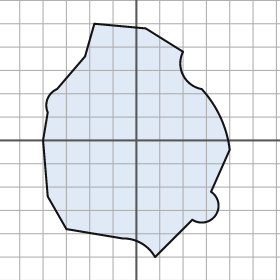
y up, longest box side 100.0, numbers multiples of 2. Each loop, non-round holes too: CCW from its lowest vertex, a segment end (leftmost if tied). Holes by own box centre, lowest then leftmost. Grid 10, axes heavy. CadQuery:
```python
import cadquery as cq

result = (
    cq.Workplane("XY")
    .moveTo(8.0, -50.0)
    .lineTo(24.0, -34.0)
    .threePointArc((34.0, -32.0), (32.0, -22.0))
    .lineTo(40.0, -4.0)
    .threePointArc((36.0, 10.0), (28.0, 22.0))
    .threePointArc((20.0, 28.0), (20.0, 38.0))
    .lineTo(4.0, 48.0)
    .lineTo(-18.0, 50.0)
    .lineTo(-22.0, 36.0)
    .lineTo(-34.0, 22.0)
    .threePointArc((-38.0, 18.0), (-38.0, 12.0))
    .lineTo(-40.0, 0.0)
    .lineTo(-38.0, -24.0)
    .lineTo(-30.0, -38.0)
    .lineTo(-6.0, -42.0)
    .threePointArc((2.0, -44.0), (8.0, -50.0))
    .close()
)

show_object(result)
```